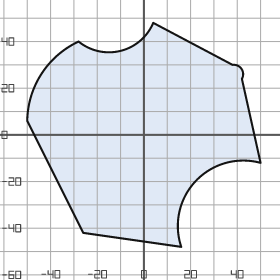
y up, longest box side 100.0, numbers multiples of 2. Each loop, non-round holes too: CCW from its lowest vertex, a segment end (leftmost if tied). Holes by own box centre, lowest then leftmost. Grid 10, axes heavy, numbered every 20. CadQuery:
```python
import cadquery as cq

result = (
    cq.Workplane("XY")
    .moveTo(16.0, -48.0)
    .threePointArc((22.0, -20.0), (50.0, -12.0))
    .lineTo(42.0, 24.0)
    .threePointArc((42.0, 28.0), (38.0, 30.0))
    .lineTo(4.0, 48.0)
    .threePointArc((-10.0, 36.0), (-28.0, 40.0))
    .threePointArc((-44.0, 26.0), (-50.0, 6.0))
    .lineTo(-26.0, -42.0)
    .close()
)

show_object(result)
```